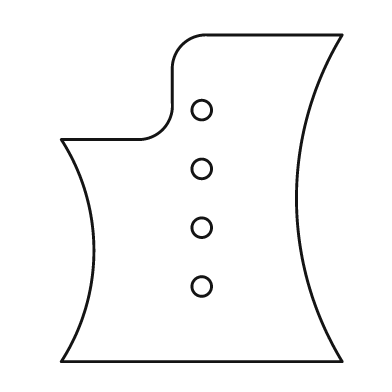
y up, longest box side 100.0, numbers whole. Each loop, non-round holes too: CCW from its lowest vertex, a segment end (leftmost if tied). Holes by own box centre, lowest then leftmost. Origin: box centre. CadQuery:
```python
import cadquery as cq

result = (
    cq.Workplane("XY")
    .moveTo(-43.0, -50.0)
    .lineTo(43.0, -50.0)
    .threePointArc((29.0, 0.0), (43.0, 50.0))
    .lineTo(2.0, 50.0)
    .threePointArc((-6.0, 47.0), (-9.0, 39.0))
    .lineTo(-9.0, 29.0)
    .threePointArc((-12.0, 21.0), (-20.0, 18.0))
    .lineTo(-43.0, 18.0)
    .threePointArc((-33.0, -16.0), (-43.0, -50.0))
    .close()
    .moveTo(0.0, -27.0)
    .circle(3.0)
    .moveTo(0.0, -9.0)
    .circle(3.0)
    .moveTo(0.0, 9.0)
    .circle(3.0)
    .moveTo(0.0, 27.0)
    .circle(3.0)
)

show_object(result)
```